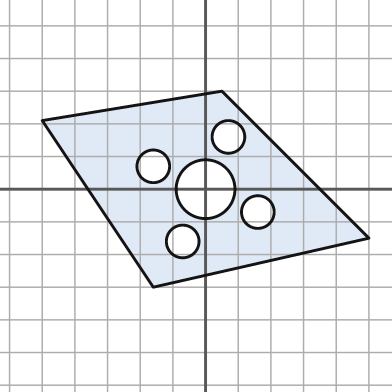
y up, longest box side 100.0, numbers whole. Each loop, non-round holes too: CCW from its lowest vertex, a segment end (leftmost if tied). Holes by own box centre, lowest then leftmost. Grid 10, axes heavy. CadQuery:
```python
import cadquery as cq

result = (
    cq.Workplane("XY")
    .moveTo(-16.0, -30.0)
    .lineTo(50.0, -15.0)
    .lineTo(5.0, 30.0)
    .lineTo(-50.0, 21.0)
    .close()
    .moveTo(-7.0, -16.0)
    .circle(5.0)
    .moveTo(16.0, -7.0)
    .circle(5.0)
    .moveTo(0.0, 0.0)
    .circle(9.0)
    .moveTo(-16.0, 7.0)
    .circle(5.0)
    .moveTo(7.0, 16.0)
    .circle(5.0)
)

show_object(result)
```